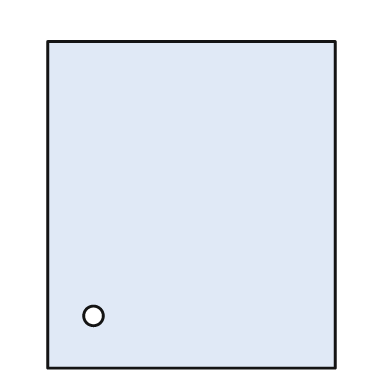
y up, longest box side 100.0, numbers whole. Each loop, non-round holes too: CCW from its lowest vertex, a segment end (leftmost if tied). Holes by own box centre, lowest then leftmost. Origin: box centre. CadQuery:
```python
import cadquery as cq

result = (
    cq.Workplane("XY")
    .moveTo(-44.0, -50.0)
    .lineTo(44.0, -50.0)
    .lineTo(44.0, 50.0)
    .lineTo(-44.0, 50.0)
    .close()
    .moveTo(-30.0, -34.0)
    .circle(3.0)
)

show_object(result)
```